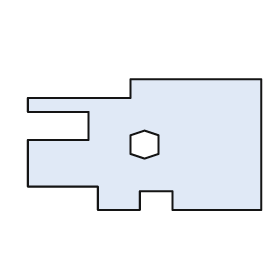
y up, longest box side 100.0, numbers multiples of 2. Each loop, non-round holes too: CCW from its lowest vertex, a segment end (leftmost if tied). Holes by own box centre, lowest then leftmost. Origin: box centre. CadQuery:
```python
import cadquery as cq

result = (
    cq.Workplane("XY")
    .moveTo(-20.0, -28.0)
    .lineTo(-2.0, -28.0)
    .lineTo(-2.0, -20.0)
    .lineTo(12.0, -20.0)
    .lineTo(12.0, -28.0)
    .lineTo(50.0, -28.0)
    .lineTo(50.0, 28.0)
    .lineTo(-6.0, 28.0)
    .lineTo(-6.0, 20.0)
    .lineTo(-50.0, 20.0)
    .lineTo(-50.0, 14.0)
    .lineTo(-24.0, 14.0)
    .lineTo(-24.0, 2.0)
    .lineTo(-50.0, 2.0)
    .lineTo(-50.0, -18.0)
    .lineTo(-20.0, -18.0)
    .close()
    .moveTo(0.0, -6.0)
    .lineTo(6.0, -4.0)
    .lineTo(6.0, 4.0)
    .lineTo(0.0, 6.0)
    .lineTo(-6.0, 4.0)
    .lineTo(-6.0, -4.0)
    .close()
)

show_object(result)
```